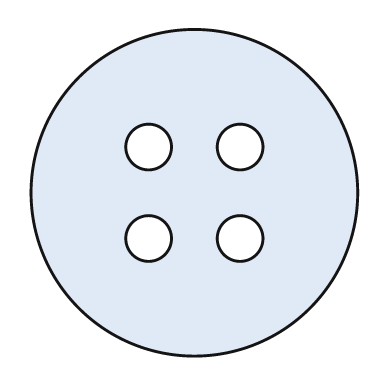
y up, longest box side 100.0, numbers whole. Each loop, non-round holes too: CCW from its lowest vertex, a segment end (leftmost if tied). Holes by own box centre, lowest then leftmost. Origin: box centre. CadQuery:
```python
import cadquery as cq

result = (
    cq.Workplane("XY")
    .moveTo(0.0, 0.0)
    .circle(50.0)
    .moveTo(-14.0, -14.0)
    .circle(7.0)
    .moveTo(14.0, -14.0)
    .circle(7.0)
    .moveTo(-14.0, 14.0)
    .circle(7.0)
    .moveTo(14.0, 14.0)
    .circle(7.0)
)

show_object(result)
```